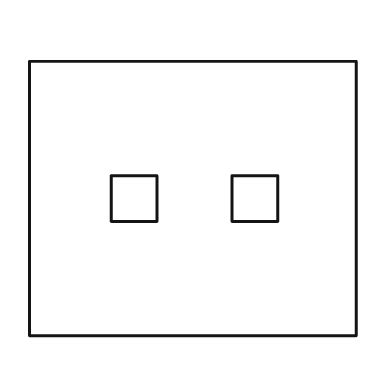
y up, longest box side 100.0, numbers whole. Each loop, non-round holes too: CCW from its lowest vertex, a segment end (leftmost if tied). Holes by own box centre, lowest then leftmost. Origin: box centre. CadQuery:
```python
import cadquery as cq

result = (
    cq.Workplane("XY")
    .moveTo(-50.0, -42.0)
    .lineTo(50.0, -42.0)
    .lineTo(50.0, 42.0)
    .lineTo(-50.0, 42.0)
    .close()
    .moveTo(-25.0, -7.0)
    .lineTo(-11.0, -7.0)
    .lineTo(-11.0, 7.0)
    .lineTo(-25.0, 7.0)
    .close()
    .moveTo(12.0, -7.0)
    .lineTo(26.0, -7.0)
    .lineTo(26.0, 7.0)
    .lineTo(12.0, 7.0)
    .close()
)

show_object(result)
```